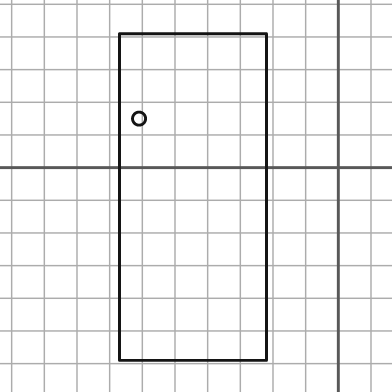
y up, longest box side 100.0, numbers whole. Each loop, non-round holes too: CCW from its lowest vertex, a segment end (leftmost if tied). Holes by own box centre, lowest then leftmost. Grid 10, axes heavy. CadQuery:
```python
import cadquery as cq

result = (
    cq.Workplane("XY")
    .moveTo(-67.0, -59.0)
    .lineTo(-22.0, -59.0)
    .lineTo(-22.0, 41.0)
    .lineTo(-67.0, 41.0)
    .close()
    .moveTo(-61.0, 15.0)
    .circle(2.0)
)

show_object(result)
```